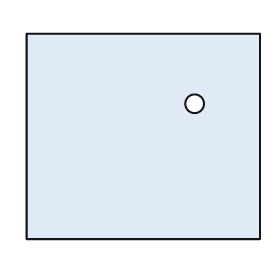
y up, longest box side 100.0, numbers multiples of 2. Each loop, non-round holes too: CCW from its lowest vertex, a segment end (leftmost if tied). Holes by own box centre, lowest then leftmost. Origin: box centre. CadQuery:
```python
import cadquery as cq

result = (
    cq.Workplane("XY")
    .moveTo(-50.0, -44.0)
    .lineTo(50.0, -44.0)
    .lineTo(50.0, 44.0)
    .lineTo(-50.0, 44.0)
    .close()
    .moveTo(22.0, 14.0)
    .circle(4.0)
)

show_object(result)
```